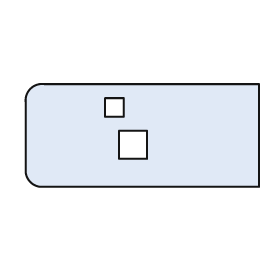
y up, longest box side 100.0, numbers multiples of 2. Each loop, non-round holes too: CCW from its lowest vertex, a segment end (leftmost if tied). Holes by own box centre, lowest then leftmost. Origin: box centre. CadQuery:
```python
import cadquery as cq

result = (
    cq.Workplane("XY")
    .moveTo(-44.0, -22.0)
    .lineTo(50.0, -22.0)
    .lineTo(50.0, 22.0)
    .lineTo(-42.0, 22.0)
    .threePointArc((-48.0, 20.0), (-50.0, 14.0))
    .lineTo(-50.0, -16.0)
    .threePointArc((-48.0, -20.0), (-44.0, -22.0))
    .close()
    .moveTo(-10.0, -10.0)
    .lineTo(2.0, -10.0)
    .lineTo(2.0, 2.0)
    .lineTo(-10.0, 2.0)
    .close()
    .moveTo(-16.0, 8.0)
    .lineTo(-8.0, 8.0)
    .lineTo(-8.0, 16.0)
    .lineTo(-16.0, 16.0)
    .close()
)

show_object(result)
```